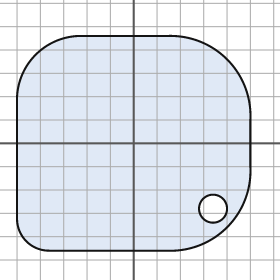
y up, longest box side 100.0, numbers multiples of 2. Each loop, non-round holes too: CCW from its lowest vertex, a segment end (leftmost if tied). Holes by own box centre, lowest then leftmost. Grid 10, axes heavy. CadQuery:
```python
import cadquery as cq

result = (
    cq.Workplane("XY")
    .moveTo(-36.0, -46.0)
    .lineTo(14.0, -46.0)
    .threePointArc((40.0, -36.0), (50.0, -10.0))
    .lineTo(50.0, 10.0)
    .threePointArc((40.0, 36.0), (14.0, 46.0))
    .lineTo(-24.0, 46.0)
    .threePointArc((-42.0, 38.0), (-50.0, 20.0))
    .lineTo(-50.0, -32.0)
    .threePointArc((-46.0, -42.0), (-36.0, -46.0))
    .close()
    .moveTo(34.0, -28.0)
    .circle(6.0)
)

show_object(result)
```